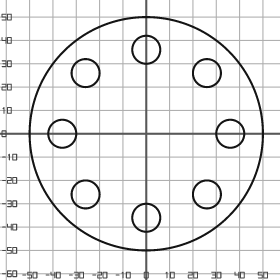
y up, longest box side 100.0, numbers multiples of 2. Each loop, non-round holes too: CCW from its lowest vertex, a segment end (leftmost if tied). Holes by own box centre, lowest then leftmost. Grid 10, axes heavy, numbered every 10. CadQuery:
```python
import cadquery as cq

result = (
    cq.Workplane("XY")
    .moveTo(0.0, 0.0)
    .circle(50.0)
    .moveTo(0.0, -36.0)
    .circle(6.0)
    .moveTo(-26.0, -26.0)
    .circle(6.0)
    .moveTo(26.0, -26.0)
    .circle(6.0)
    .moveTo(-36.0, 0.0)
    .circle(6.0)
    .moveTo(36.0, 0.0)
    .circle(6.0)
    .moveTo(-26.0, 26.0)
    .circle(6.0)
    .moveTo(26.0, 26.0)
    .circle(6.0)
    .moveTo(0.0, 36.0)
    .circle(6.0)
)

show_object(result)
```